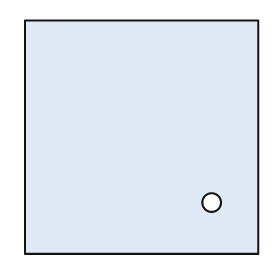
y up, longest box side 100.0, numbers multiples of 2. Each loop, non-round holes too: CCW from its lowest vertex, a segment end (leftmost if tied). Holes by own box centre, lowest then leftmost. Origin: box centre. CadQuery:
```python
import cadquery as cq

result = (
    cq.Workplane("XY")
    .moveTo(-50.0, -50.0)
    .lineTo(50.0, -50.0)
    .lineTo(50.0, 50.0)
    .lineTo(-50.0, 50.0)
    .close()
    .moveTo(30.0, -28.0)
    .circle(4.0)
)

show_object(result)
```